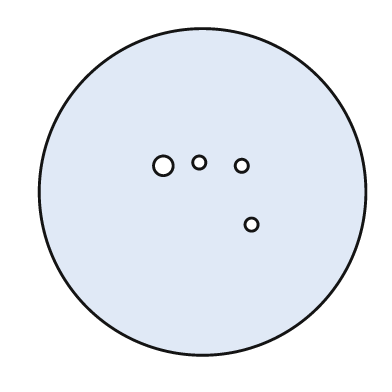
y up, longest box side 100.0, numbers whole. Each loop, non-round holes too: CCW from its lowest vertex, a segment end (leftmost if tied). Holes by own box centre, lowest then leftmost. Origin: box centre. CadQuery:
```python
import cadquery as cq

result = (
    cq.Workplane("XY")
    .moveTo(0.0, 0.0)
    .circle(50.0)
    .moveTo(15.0, -10.0)
    .circle(2.0)
    .moveTo(-12.0, 8.0)
    .circle(3.0)
    .moveTo(12.0, 8.0)
    .circle(2.0)
    .moveTo(-1.0, 9.0)
    .circle(2.0)
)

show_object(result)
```